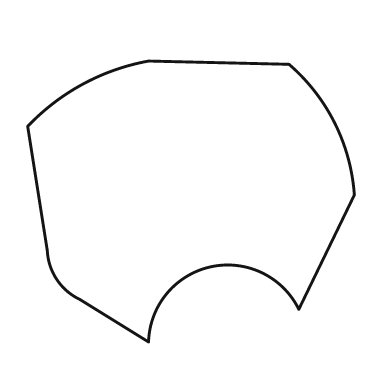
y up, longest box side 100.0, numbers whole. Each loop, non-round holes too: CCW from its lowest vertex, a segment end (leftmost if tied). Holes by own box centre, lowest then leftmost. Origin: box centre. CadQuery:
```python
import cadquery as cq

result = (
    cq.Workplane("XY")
    .moveTo(-13.0, -43.0)
    .threePointArc((6.0, -20.0), (33.0, -33.0))
    .lineTo(50.0, 2.0)
    .threePointArc((44.0, 24.0), (30.0, 42.0))
    .lineTo(-13.0, 43.0)
    .threePointArc((-33.0, 36.0), (-50.0, 23.0))
    .lineTo(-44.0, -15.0)
    .threePointArc((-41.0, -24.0), (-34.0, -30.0))
    .close()
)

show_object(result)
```